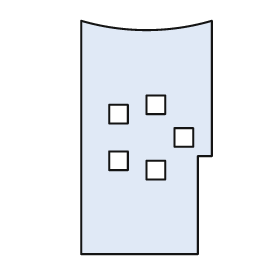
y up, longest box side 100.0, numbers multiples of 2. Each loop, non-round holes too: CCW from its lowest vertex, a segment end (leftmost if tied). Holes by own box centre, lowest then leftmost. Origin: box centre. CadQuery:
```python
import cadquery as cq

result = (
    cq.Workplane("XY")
    .moveTo(-28.0, -50.0)
    .lineTo(22.0, -50.0)
    .lineTo(22.0, -8.0)
    .lineTo(28.0, -8.0)
    .lineTo(28.0, 50.0)
    .threePointArc((0.0, 46.0), (-28.0, 50.0))
    .close()
    .moveTo(0.0, -18.0)
    .lineTo(8.0, -18.0)
    .lineTo(8.0, -10.0)
    .lineTo(0.0, -10.0)
    .close()
    .moveTo(-16.0, -14.0)
    .lineTo(-8.0, -14.0)
    .lineTo(-8.0, -6.0)
    .lineTo(-16.0, -6.0)
    .close()
    .moveTo(12.0, -4.0)
    .lineTo(20.0, -4.0)
    .lineTo(20.0, 4.0)
    .lineTo(12.0, 4.0)
    .close()
    .moveTo(-16.0, 6.0)
    .lineTo(-8.0, 6.0)
    .lineTo(-8.0, 14.0)
    .lineTo(-16.0, 14.0)
    .close()
    .moveTo(0.0, 10.0)
    .lineTo(8.0, 10.0)
    .lineTo(8.0, 18.0)
    .lineTo(0.0, 18.0)
    .close()
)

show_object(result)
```